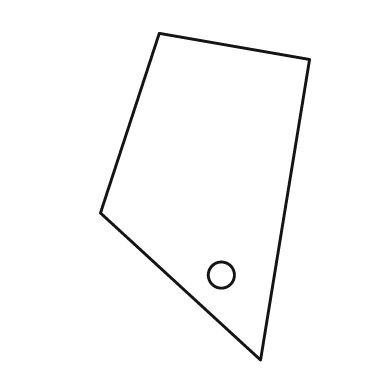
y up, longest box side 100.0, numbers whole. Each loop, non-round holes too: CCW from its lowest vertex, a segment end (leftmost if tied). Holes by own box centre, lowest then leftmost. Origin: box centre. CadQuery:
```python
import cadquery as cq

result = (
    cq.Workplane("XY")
    .moveTo(17.0, -50.0)
    .lineTo(32.0, 42.0)
    .lineTo(-14.0, 50.0)
    .lineTo(-32.0, -5.0)
    .close()
    .moveTo(5.0, -24.0)
    .circle(4.0)
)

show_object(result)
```